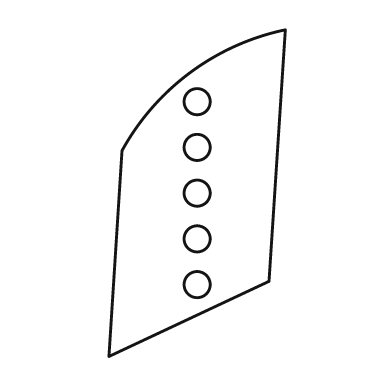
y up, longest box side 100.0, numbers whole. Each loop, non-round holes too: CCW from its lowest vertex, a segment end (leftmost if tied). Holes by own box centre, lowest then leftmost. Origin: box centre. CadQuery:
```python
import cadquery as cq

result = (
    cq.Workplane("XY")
    .moveTo(-27.0, -50.0)
    .lineTo(22.0, -27.0)
    .lineTo(27.0, 50.0)
    .threePointArc((-2.0, 37.0), (-23.0, 13.0))
    .close()
    .moveTo(0.0, -28.0)
    .circle(4.0)
    .moveTo(0.0, -14.0)
    .circle(4.0)
    .moveTo(0.0, 0.0)
    .circle(4.0)
    .moveTo(0.0, 14.0)
    .circle(4.0)
    .moveTo(0.0, 28.0)
    .circle(4.0)
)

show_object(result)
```